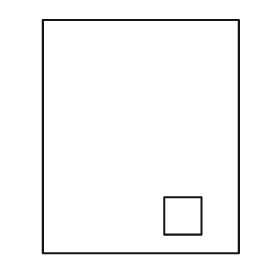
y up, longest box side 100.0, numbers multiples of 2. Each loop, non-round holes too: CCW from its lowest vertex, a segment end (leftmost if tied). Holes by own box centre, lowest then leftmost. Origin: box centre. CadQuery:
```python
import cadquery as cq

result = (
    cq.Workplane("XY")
    .moveTo(-42.0, -50.0)
    .lineTo(42.0, -50.0)
    .lineTo(42.0, 50.0)
    .lineTo(-42.0, 50.0)
    .close()
    .moveTo(10.0, -42.0)
    .lineTo(26.0, -42.0)
    .lineTo(26.0, -26.0)
    .lineTo(10.0, -26.0)
    .close()
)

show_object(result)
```